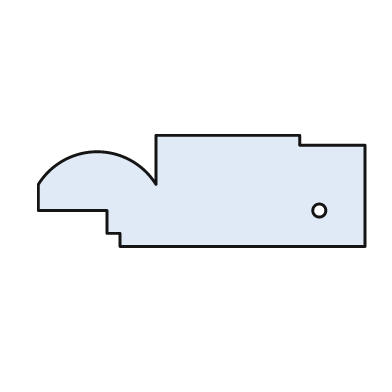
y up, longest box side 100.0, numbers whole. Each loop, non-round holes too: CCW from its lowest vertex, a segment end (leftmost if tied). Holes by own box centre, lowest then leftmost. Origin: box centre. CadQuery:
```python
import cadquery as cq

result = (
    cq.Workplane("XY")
    .moveTo(-25.0, -17.0)
    .lineTo(50.0, -17.0)
    .lineTo(50.0, 14.0)
    .lineTo(30.0, 14.0)
    .lineTo(30.0, 17.0)
    .lineTo(-14.0, 17.0)
    .lineTo(-14.0, 2.0)
    .threePointArc((-32.0, 12.0), (-50.0, 2.0))
    .lineTo(-50.0, -6.0)
    .lineTo(-29.0, -6.0)
    .lineTo(-29.0, -13.0)
    .lineTo(-25.0, -13.0)
    .close()
    .moveTo(36.0, -6.0)
    .circle(2.0)
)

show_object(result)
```